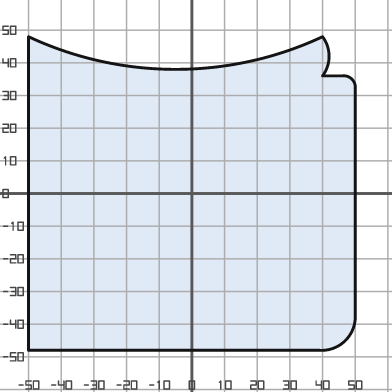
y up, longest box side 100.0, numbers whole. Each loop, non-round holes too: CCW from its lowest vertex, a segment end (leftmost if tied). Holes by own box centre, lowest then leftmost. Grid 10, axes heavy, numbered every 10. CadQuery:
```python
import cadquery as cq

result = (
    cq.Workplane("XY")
    .moveTo(-50.0, -48.0)
    .lineTo(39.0, -48.0)
    .threePointArc((47.0, -45.0), (50.0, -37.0))
    .lineTo(50.0, 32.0)
    .threePointArc((49.0, 35.0), (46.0, 36.0))
    .lineTo(40.0, 36.0)
    .threePointArc((42.0, 42.0), (40.0, 48.0))
    .threePointArc((-5.0, 38.0), (-50.0, 48.0))
    .close()
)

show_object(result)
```